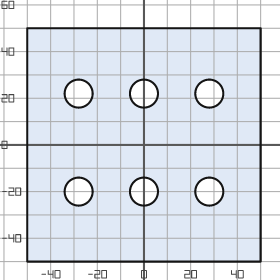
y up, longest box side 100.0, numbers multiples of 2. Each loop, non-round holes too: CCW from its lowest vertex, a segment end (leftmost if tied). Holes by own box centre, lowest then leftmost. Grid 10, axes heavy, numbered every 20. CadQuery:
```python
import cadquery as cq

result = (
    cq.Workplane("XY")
    .moveTo(-50.0, -50.0)
    .lineTo(50.0, -50.0)
    .lineTo(50.0, 50.0)
    .lineTo(-50.0, 50.0)
    .close()
    .moveTo(-28.0, -20.0)
    .circle(6.0)
    .moveTo(0.0, -20.0)
    .circle(6.0)
    .moveTo(28.0, -20.0)
    .circle(6.0)
    .moveTo(-28.0, 22.0)
    .circle(6.0)
    .moveTo(0.0, 22.0)
    .circle(6.0)
    .moveTo(28.0, 22.0)
    .circle(6.0)
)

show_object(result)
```